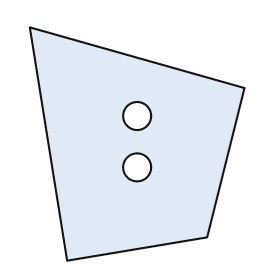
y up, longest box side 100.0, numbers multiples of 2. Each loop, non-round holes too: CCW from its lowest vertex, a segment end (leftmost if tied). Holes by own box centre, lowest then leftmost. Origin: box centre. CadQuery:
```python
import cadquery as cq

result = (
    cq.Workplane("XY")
    .moveTo(-30.0, -50.0)
    .lineTo(30.0, -40.0)
    .lineTo(46.0, 24.0)
    .lineTo(-46.0, 50.0)
    .close()
    .moveTo(0.0, -10.0)
    .circle(6.0)
    .moveTo(0.0, 12.0)
    .circle(6.0)
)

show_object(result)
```